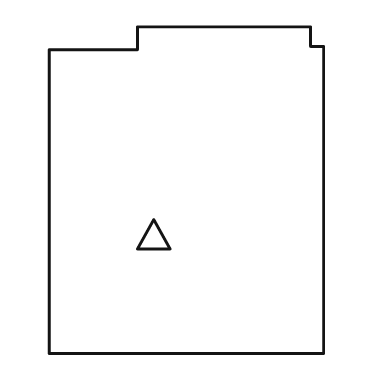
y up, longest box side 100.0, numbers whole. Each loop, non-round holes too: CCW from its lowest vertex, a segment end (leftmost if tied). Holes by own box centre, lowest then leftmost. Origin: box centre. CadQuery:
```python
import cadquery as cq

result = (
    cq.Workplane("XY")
    .moveTo(-42.0, -50.0)
    .lineTo(42.0, -50.0)
    .lineTo(42.0, 44.0)
    .lineTo(38.0, 44.0)
    .lineTo(38.0, 50.0)
    .lineTo(-15.0, 50.0)
    .lineTo(-15.0, 43.0)
    .lineTo(-42.0, 43.0)
    .close()
    .moveTo(-15.0, -18.0)
    .lineTo(-5.0, -18.0)
    .lineTo(-10.0, -9.0)
    .close()
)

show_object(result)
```